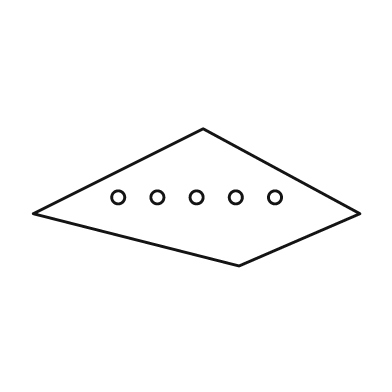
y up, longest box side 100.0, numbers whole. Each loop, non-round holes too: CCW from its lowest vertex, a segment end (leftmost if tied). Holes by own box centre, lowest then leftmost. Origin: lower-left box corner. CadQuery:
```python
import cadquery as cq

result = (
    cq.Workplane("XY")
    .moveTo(63.0, 0.0)
    .lineTo(100.0, 16.0)
    .lineTo(52.0, 42.0)
    .lineTo(0.0, 16.0)
    .close()
    .moveTo(26.0, 21.0)
    .circle(2.0)
    .moveTo(38.0, 21.0)
    .circle(2.0)
    .moveTo(50.0, 21.0)
    .circle(2.0)
    .moveTo(62.0, 21.0)
    .circle(2.0)
    .moveTo(74.0, 21.0)
    .circle(2.0)
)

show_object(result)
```